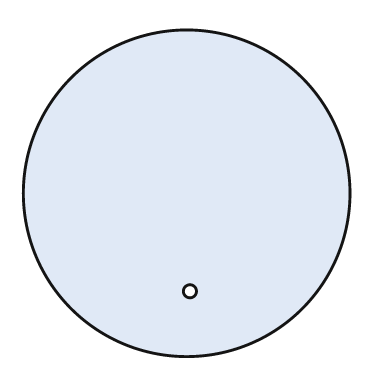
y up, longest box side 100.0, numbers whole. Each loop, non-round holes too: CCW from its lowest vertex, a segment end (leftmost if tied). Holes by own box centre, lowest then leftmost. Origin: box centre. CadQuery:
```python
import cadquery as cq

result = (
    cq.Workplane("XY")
    .moveTo(0.0, 0.0)
    .circle(50.0)
    .moveTo(1.0, -30.0)
    .circle(2.0)
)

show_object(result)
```